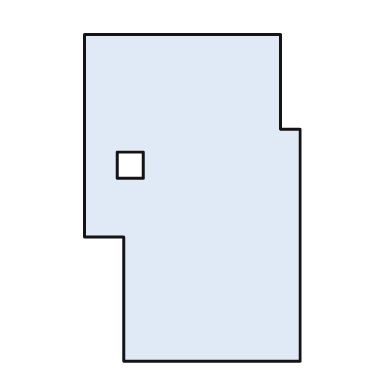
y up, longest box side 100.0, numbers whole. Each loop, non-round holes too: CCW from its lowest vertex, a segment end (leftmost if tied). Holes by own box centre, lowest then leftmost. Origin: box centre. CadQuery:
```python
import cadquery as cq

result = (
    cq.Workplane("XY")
    .moveTo(-21.0, -50.0)
    .lineTo(33.0, -50.0)
    .lineTo(33.0, 21.0)
    .lineTo(27.0, 21.0)
    .lineTo(27.0, 50.0)
    .lineTo(-33.0, 50.0)
    .lineTo(-33.0, -12.0)
    .lineTo(-21.0, -12.0)
    .close()
    .moveTo(-23.0, 6.0)
    .lineTo(-15.0, 6.0)
    .lineTo(-15.0, 14.0)
    .lineTo(-23.0, 14.0)
    .close()
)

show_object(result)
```